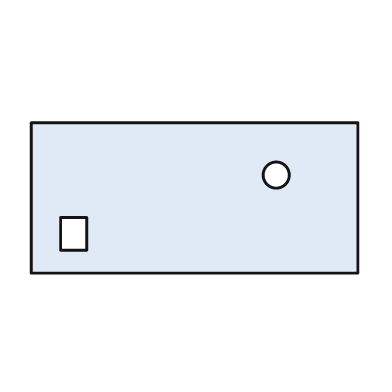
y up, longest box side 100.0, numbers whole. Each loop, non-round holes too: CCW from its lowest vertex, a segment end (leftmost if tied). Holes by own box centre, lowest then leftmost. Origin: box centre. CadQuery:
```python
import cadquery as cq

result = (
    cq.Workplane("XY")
    .moveTo(-50.0, -23.0)
    .lineTo(50.0, -23.0)
    .lineTo(50.0, 23.0)
    .lineTo(-50.0, 23.0)
    .close()
    .moveTo(-41.0, -16.0)
    .lineTo(-33.0, -16.0)
    .lineTo(-33.0, -6.0)
    .lineTo(-41.0, -6.0)
    .close()
    .moveTo(25.0, 7.0)
    .circle(4.0)
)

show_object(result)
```